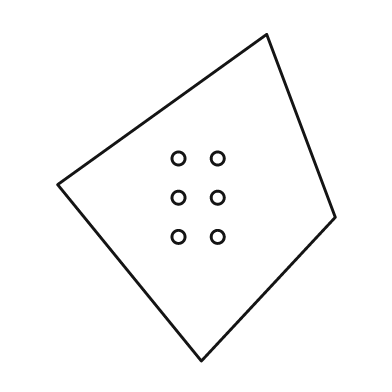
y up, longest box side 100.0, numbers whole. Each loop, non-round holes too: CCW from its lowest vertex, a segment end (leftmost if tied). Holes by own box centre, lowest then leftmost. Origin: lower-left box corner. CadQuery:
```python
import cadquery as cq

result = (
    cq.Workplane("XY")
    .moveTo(44.0, 0.0)
    .lineTo(85.0, 44.0)
    .lineTo(64.0, 100.0)
    .lineTo(0.0, 54.0)
    .close()
    .moveTo(37.0, 38.0)
    .circle(2.0)
    .moveTo(49.0, 38.0)
    .circle(2.0)
    .moveTo(37.0, 50.0)
    .circle(2.0)
    .moveTo(49.0, 50.0)
    .circle(2.0)
    .moveTo(37.0, 62.0)
    .circle(2.0)
    .moveTo(49.0, 62.0)
    .circle(2.0)
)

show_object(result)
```